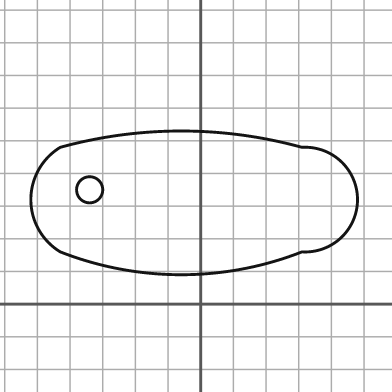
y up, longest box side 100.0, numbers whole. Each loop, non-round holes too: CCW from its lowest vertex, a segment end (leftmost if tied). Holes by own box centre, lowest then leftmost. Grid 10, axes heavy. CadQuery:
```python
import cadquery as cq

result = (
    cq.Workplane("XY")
    .moveTo(-43.0, 16.0)
    .threePointArc((-6.0, 9.0), (31.0, 16.0))
    .threePointArc((48.0, 32.0), (31.0, 48.0))
    .threePointArc((-6.0, 53.0), (-43.0, 48.0))
    .threePointArc((-52.0, 32.0), (-43.0, 16.0))
    .close()
    .moveTo(-34.0, 35.0)
    .circle(4.0)
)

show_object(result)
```